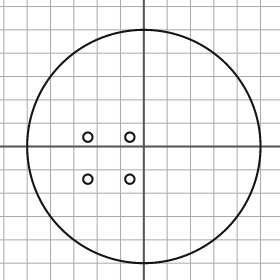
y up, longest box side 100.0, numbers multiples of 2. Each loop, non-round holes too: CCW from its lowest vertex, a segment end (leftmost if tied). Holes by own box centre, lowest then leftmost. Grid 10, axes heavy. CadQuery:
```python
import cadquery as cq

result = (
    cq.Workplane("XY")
    .moveTo(0.0, 0.0)
    .circle(50.0)
    .moveTo(-24.0, -14.0)
    .circle(2.0)
    .moveTo(-6.0, -14.0)
    .circle(2.0)
    .moveTo(-24.0, 4.0)
    .circle(2.0)
    .moveTo(-6.0, 4.0)
    .circle(2.0)
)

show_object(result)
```